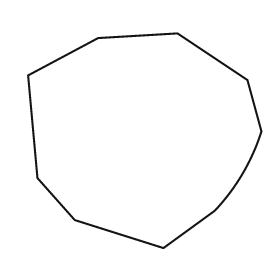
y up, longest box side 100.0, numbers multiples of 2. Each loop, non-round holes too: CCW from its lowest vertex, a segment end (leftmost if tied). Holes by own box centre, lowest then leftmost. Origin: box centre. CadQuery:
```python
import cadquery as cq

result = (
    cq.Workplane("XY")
    .moveTo(8.0, -46.0)
    .lineTo(30.0, -30.0)
    .threePointArc((42.0, -14.0), (50.0, 4.0))
    .lineTo(44.0, 26.0)
    .lineTo(14.0, 46.0)
    .lineTo(-20.0, 44.0)
    .lineTo(-50.0, 28.0)
    .lineTo(-46.0, -16.0)
    .lineTo(-30.0, -34.0)
    .close()
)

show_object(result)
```